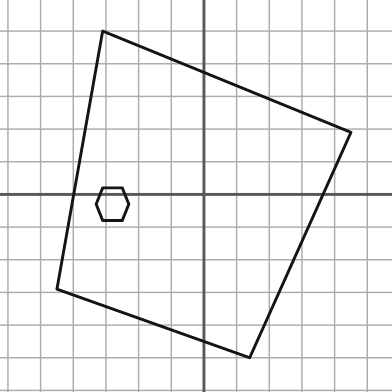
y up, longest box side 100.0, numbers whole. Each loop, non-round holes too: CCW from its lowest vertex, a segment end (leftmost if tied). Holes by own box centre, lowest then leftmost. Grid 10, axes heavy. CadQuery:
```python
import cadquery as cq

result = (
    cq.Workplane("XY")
    .moveTo(14.0, -50.0)
    .lineTo(45.0, 19.0)
    .lineTo(-31.0, 50.0)
    .lineTo(-45.0, -29.0)
    .close()
    .moveTo(-31.0, -8.0)
    .lineTo(-25.0, -8.0)
    .lineTo(-23.0, -3.0)
    .lineTo(-25.0, 2.0)
    .lineTo(-31.0, 2.0)
    .lineTo(-33.0, -3.0)
    .close()
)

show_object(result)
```